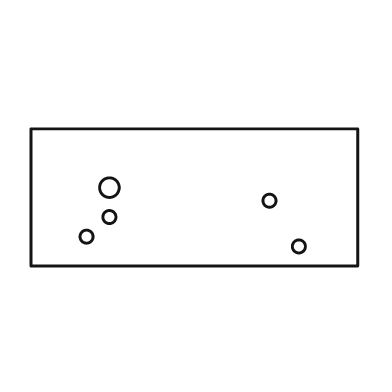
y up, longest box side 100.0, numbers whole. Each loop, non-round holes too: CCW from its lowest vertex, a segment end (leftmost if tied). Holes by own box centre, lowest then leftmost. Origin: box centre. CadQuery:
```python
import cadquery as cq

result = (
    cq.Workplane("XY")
    .moveTo(-50.0, -21.0)
    .lineTo(50.0, -21.0)
    .lineTo(50.0, 21.0)
    .lineTo(-50.0, 21.0)
    .close()
    .moveTo(32.0, -15.0)
    .circle(2.0)
    .moveTo(-33.0, -12.0)
    .circle(2.0)
    .moveTo(-26.0, -6.0)
    .circle(2.0)
    .moveTo(23.0, -1.0)
    .circle(2.0)
    .moveTo(-26.0, 3.0)
    .circle(3.0)
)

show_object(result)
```